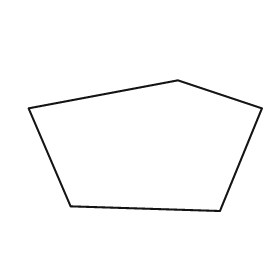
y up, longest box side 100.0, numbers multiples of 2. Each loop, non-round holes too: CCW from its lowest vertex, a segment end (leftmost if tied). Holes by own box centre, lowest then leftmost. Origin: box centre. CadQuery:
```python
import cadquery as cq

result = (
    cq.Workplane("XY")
    .moveTo(32.0, -28.0)
    .lineTo(50.0, 16.0)
    .lineTo(14.0, 28.0)
    .lineTo(-50.0, 16.0)
    .lineTo(-32.0, -26.0)
    .close()
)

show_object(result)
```